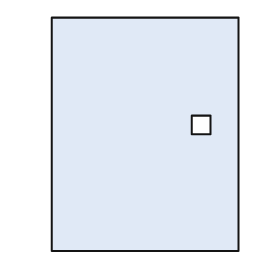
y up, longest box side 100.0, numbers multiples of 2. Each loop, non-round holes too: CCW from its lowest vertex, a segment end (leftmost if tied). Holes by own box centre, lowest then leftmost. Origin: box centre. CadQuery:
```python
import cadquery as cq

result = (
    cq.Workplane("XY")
    .moveTo(-40.0, -50.0)
    .lineTo(40.0, -50.0)
    .lineTo(40.0, 50.0)
    .lineTo(-40.0, 50.0)
    .close()
    .moveTo(20.0, 0.0)
    .lineTo(28.0, 0.0)
    .lineTo(28.0, 8.0)
    .lineTo(20.0, 8.0)
    .close()
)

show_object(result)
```